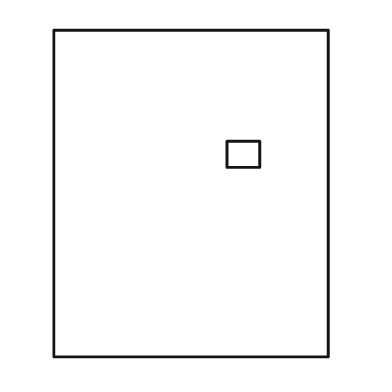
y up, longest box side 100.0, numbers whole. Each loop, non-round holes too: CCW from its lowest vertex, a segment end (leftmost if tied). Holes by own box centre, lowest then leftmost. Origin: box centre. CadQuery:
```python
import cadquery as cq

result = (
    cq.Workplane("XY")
    .moveTo(-42.0, -50.0)
    .lineTo(42.0, -50.0)
    .lineTo(42.0, 50.0)
    .lineTo(-42.0, 50.0)
    .close()
    .moveTo(11.0, 8.0)
    .lineTo(21.0, 8.0)
    .lineTo(21.0, 16.0)
    .lineTo(11.0, 16.0)
    .close()
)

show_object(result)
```